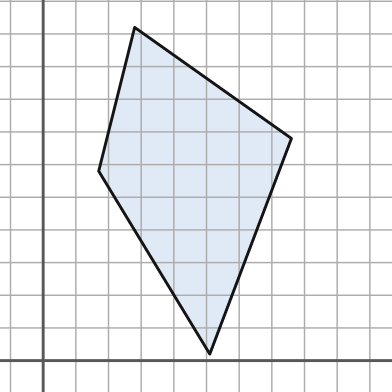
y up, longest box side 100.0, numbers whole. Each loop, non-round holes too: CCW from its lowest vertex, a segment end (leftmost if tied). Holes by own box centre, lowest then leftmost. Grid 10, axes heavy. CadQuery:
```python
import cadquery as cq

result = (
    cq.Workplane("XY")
    .moveTo(51.0, 2.0)
    .lineTo(76.0, 68.0)
    .lineTo(28.0, 102.0)
    .lineTo(17.0, 58.0)
    .close()
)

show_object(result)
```